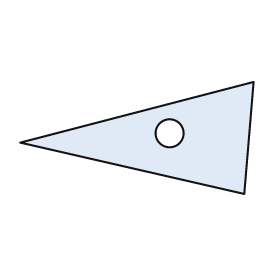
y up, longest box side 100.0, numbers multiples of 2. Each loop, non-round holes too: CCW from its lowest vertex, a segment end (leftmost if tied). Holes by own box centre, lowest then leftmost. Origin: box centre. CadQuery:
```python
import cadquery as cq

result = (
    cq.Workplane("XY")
    .moveTo(46.0, -24.0)
    .lineTo(50.0, 24.0)
    .lineTo(-50.0, -2.0)
    .close()
    .moveTo(14.0, 2.0)
    .circle(6.0)
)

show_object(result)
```